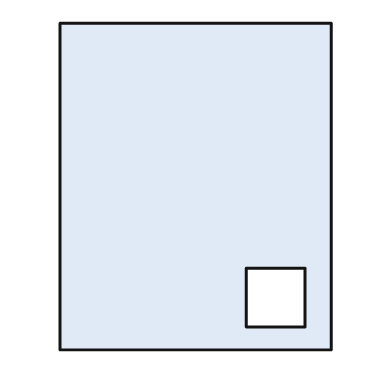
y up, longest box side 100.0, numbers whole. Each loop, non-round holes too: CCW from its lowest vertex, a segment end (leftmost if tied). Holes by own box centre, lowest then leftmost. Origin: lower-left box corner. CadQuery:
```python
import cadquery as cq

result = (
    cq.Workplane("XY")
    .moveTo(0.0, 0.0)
    .lineTo(83.0, 0.0)
    .lineTo(83.0, 100.0)
    .lineTo(0.0, 100.0)
    .close()
    .moveTo(57.0, 7.0)
    .lineTo(75.0, 7.0)
    .lineTo(75.0, 25.0)
    .lineTo(57.0, 25.0)
    .close()
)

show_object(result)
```